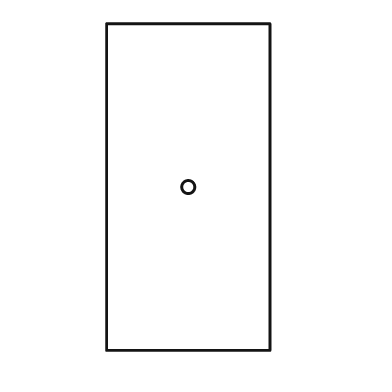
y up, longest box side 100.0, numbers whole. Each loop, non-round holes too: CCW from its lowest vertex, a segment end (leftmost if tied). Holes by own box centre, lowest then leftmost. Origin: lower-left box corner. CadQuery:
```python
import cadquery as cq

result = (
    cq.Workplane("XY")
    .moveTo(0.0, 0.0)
    .lineTo(50.0, 0.0)
    .lineTo(50.0, 100.0)
    .lineTo(0.0, 100.0)
    .close()
    .moveTo(25.0, 50.0)
    .circle(2.0)
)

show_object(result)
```